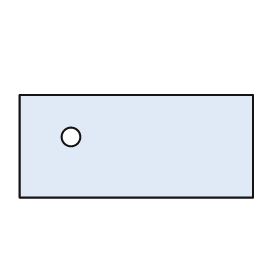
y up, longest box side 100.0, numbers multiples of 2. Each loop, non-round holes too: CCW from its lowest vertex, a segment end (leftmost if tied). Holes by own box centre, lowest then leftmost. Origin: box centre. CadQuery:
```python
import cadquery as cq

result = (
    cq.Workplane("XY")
    .moveTo(-50.0, -22.0)
    .lineTo(50.0, -22.0)
    .lineTo(50.0, 22.0)
    .lineTo(-50.0, 22.0)
    .close()
    .moveTo(-28.0, 4.0)
    .circle(4.0)
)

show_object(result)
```